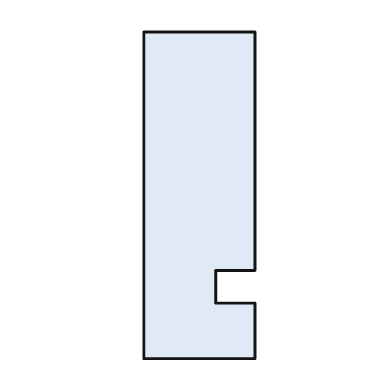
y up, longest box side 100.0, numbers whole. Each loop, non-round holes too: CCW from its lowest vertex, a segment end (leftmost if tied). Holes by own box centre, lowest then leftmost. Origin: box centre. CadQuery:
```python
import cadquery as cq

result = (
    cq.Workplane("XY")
    .moveTo(-17.0, -50.0)
    .lineTo(17.0, -50.0)
    .lineTo(17.0, -33.0)
    .lineTo(5.0, -33.0)
    .lineTo(5.0, -23.0)
    .lineTo(17.0, -23.0)
    .lineTo(17.0, 50.0)
    .lineTo(-17.0, 50.0)
    .close()
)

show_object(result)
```